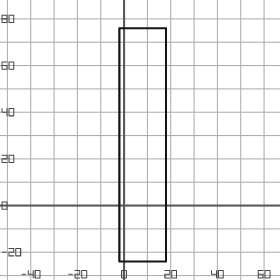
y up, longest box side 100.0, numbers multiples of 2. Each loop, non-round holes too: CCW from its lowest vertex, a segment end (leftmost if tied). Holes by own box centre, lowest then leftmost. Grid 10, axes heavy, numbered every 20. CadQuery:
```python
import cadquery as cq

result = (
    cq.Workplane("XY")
    .moveTo(-2.0, -24.0)
    .lineTo(18.0, -24.0)
    .lineTo(18.0, 76.0)
    .lineTo(-2.0, 76.0)
    .close()
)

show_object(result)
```